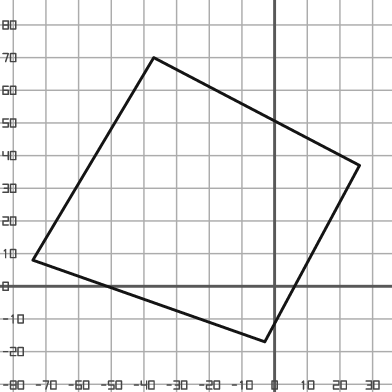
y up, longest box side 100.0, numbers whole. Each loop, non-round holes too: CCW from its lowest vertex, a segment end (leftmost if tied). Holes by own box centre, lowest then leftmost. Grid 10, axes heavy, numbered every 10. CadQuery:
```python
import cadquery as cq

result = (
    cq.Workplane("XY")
    .moveTo(-3.0, -17.0)
    .lineTo(26.0, 37.0)
    .lineTo(-37.0, 70.0)
    .lineTo(-74.0, 8.0)
    .close()
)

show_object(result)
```